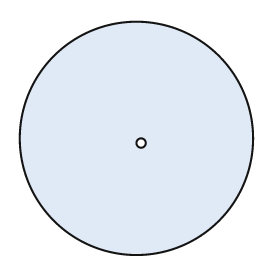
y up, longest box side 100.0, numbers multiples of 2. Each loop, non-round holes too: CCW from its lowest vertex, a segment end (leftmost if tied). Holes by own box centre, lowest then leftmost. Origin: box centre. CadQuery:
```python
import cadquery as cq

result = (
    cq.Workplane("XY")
    .moveTo(0.0, 0.0)
    .circle(50.0)
    .moveTo(2.0, -2.0)
    .circle(2.0)
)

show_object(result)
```